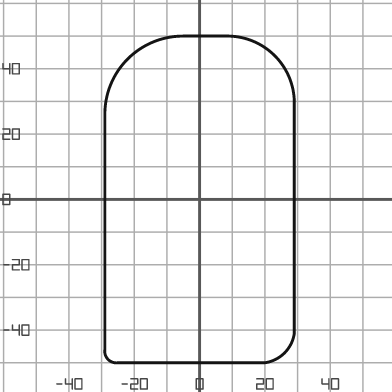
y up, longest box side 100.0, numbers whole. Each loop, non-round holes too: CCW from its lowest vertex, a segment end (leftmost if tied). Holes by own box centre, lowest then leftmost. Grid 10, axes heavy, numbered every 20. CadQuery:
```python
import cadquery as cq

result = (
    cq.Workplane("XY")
    .moveTo(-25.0, -50.0)
    .lineTo(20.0, -50.0)
    .threePointArc((26.0, -47.0), (29.0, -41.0))
    .lineTo(29.0, 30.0)
    .threePointArc((23.0, 44.0), (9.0, 50.0))
    .lineTo(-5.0, 50.0)
    .threePointArc((-22.0, 43.0), (-29.0, 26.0))
    .lineTo(-29.0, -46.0)
    .threePointArc((-28.0, -49.0), (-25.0, -50.0))
    .close()
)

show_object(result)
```